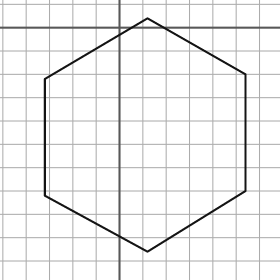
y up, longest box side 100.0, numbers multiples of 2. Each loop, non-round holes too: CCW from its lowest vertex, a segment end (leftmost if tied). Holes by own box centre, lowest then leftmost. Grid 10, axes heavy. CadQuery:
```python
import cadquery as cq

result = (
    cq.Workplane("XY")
    .moveTo(12.0, -96.0)
    .lineTo(54.0, -70.0)
    .lineTo(54.0, -20.0)
    .lineTo(12.0, 4.0)
    .lineTo(-32.0, -22.0)
    .lineTo(-32.0, -72.0)
    .close()
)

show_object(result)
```